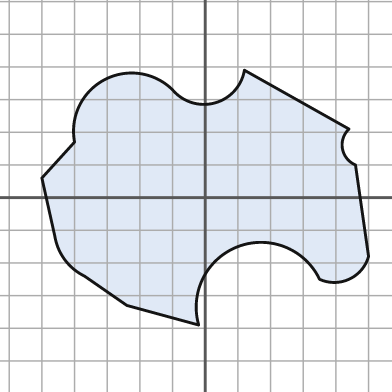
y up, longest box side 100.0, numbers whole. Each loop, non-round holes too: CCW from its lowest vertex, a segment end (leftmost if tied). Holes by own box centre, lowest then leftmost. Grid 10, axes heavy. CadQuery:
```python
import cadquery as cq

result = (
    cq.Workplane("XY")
    .moveTo(-2.0, -39.0)
    .threePointArc((10.0, -15.0), (35.0, -25.0))
    .threePointArc((44.0, -25.0), (50.0, -18.0))
    .lineTo(46.0, 10.0)
    .threePointArc((42.0, 15.0), (44.0, 21.0))
    .lineTo(12.0, 39.0)
    .threePointArc((3.0, 29.0), (-10.0, 33.0))
    .threePointArc((-31.0, 36.0), (-40.0, 17.0))
    .lineTo(-50.0, 6.0)
    .lineTo(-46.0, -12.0)
    .threePointArc((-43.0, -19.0), (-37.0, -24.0))
    .lineTo(-24.0, -33.0)
    .close()
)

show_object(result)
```